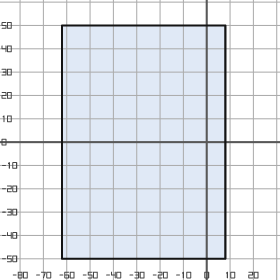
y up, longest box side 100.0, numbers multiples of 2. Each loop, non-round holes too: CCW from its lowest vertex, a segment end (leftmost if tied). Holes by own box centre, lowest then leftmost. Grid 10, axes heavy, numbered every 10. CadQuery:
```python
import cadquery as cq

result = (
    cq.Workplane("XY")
    .moveTo(-62.0, -50.0)
    .lineTo(8.0, -50.0)
    .lineTo(8.0, 50.0)
    .lineTo(-62.0, 50.0)
    .close()
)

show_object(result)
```